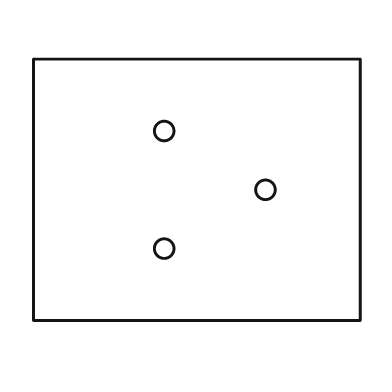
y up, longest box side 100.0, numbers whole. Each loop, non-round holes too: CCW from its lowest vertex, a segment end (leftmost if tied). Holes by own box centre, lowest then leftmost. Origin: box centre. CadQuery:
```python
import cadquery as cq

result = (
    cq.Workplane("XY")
    .moveTo(-50.0, -40.0)
    .lineTo(50.0, -40.0)
    .lineTo(50.0, 40.0)
    .lineTo(-50.0, 40.0)
    .close()
    .moveTo(-10.0, -18.0)
    .circle(3.0)
    .moveTo(21.0, 0.0)
    .circle(3.0)
    .moveTo(-10.0, 18.0)
    .circle(3.0)
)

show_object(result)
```